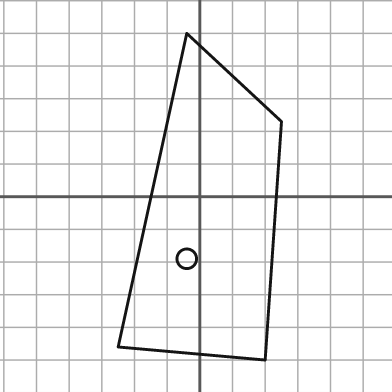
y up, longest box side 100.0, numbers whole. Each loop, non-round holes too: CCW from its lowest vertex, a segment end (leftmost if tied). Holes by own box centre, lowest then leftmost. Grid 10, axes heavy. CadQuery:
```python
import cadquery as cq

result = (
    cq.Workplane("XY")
    .moveTo(20.0, -50.0)
    .lineTo(25.0, 23.0)
    .lineTo(-4.0, 50.0)
    .lineTo(-25.0, -46.0)
    .close()
    .moveTo(-4.0, -19.0)
    .circle(3.0)
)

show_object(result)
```